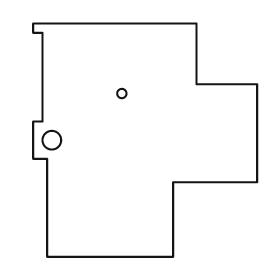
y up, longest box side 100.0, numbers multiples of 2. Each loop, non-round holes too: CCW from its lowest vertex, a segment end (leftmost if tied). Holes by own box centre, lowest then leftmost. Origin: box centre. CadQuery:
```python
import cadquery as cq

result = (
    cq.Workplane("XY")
    .moveTo(-42.0, -50.0)
    .lineTo(12.0, -50.0)
    .lineTo(12.0, -18.0)
    .lineTo(48.0, -18.0)
    .lineTo(48.0, 24.0)
    .lineTo(22.0, 24.0)
    .lineTo(22.0, 50.0)
    .lineTo(-48.0, 50.0)
    .lineTo(-48.0, 46.0)
    .lineTo(-44.0, 46.0)
    .lineTo(-44.0, 8.0)
    .lineTo(-48.0, 8.0)
    .lineTo(-48.0, -8.0)
    .lineTo(-42.0, -8.0)
    .close()
    .moveTo(-40.0, 0.0)
    .circle(4.0)
    .moveTo(-10.0, 20.0)
    .circle(2.0)
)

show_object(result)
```